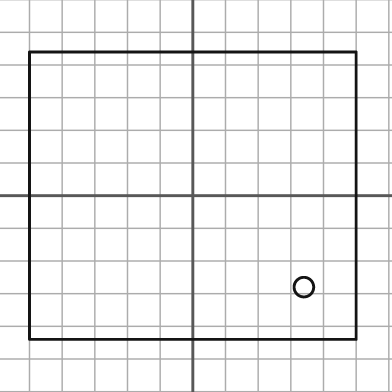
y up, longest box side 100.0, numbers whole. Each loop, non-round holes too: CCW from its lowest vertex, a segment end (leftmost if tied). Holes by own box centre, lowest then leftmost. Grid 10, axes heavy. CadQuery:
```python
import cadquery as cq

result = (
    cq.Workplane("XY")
    .moveTo(-50.0, -44.0)
    .lineTo(50.0, -44.0)
    .lineTo(50.0, 44.0)
    .lineTo(-50.0, 44.0)
    .close()
    .moveTo(34.0, -28.0)
    .circle(3.0)
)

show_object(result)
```